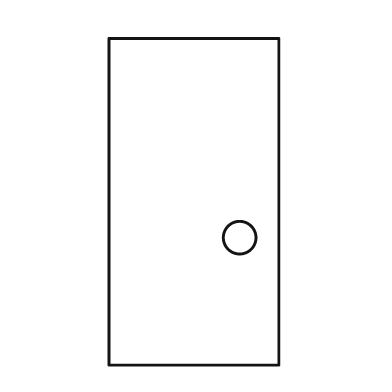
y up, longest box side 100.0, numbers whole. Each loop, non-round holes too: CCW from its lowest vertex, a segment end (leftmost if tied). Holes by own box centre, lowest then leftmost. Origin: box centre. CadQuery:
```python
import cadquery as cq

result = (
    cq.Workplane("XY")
    .moveTo(-26.0, -50.0)
    .lineTo(26.0, -50.0)
    .lineTo(26.0, 50.0)
    .lineTo(-26.0, 50.0)
    .close()
    .moveTo(14.0, -11.0)
    .circle(5.0)
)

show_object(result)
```